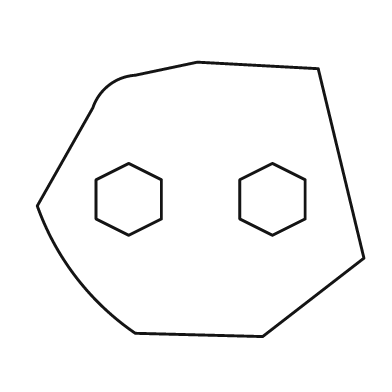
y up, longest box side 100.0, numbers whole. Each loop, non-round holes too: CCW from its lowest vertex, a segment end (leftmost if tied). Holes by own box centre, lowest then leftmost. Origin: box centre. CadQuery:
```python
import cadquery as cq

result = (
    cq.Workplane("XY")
    .moveTo(19.0, -42.0)
    .lineTo(50.0, -18.0)
    .lineTo(36.0, 40.0)
    .lineTo(-1.0, 42.0)
    .lineTo(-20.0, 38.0)
    .threePointArc((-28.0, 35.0), (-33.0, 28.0))
    .lineTo(-50.0, -2.0)
    .threePointArc((-38.0, -24.0), (-20.0, -41.0))
    .close()
    .moveTo(-22.0, -11.0)
    .lineTo(-12.0, -6.0)
    .lineTo(-12.0, 6.0)
    .lineTo(-22.0, 11.0)
    .lineTo(-32.0, 6.0)
    .lineTo(-32.0, -6.0)
    .close()
    .moveTo(22.0, -11.0)
    .lineTo(32.0, -6.0)
    .lineTo(32.0, 6.0)
    .lineTo(22.0, 11.0)
    .lineTo(12.0, 6.0)
    .lineTo(12.0, -6.0)
    .close()
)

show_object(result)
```